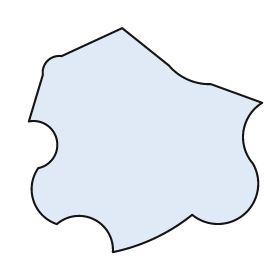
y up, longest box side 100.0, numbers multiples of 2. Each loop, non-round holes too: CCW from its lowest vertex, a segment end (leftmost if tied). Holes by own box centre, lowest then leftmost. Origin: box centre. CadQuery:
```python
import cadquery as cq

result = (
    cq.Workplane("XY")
    .moveTo(-14.0, -48.0)
    .threePointArc((4.0, -42.0), (20.0, -32.0))
    .threePointArc((42.0, -32.0), (46.0, -10.0))
    .threePointArc((42.0, 4.0), (50.0, 16.0))
    .lineTo(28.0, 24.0)
    .threePointArc((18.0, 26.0), (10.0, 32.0))
    .lineTo(-10.0, 48.0)
    .lineTo(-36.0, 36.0)
    .threePointArc((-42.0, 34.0), (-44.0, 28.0))
    .lineTo(-50.0, 8.0)
    .threePointArc((-38.0, 0.0), (-46.0, -12.0))
    .threePointArc((-48.0, -26.0), (-38.0, -36.0))
    .threePointArc((-22.0, -34.0), (-14.0, -48.0))
    .close()
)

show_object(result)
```